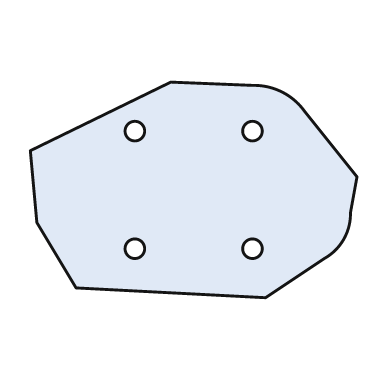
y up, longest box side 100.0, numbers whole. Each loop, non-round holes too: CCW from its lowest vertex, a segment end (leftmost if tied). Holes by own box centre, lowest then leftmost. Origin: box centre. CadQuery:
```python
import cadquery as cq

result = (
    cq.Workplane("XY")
    .moveTo(22.0, -33.0)
    .lineTo(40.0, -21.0)
    .threePointArc((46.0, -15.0), (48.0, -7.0))
    .lineTo(50.0, 4.0)
    .lineTo(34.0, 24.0)
    .threePointArc((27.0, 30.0), (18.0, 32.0))
    .lineTo(-7.0, 33.0)
    .lineTo(-50.0, 12.0)
    .lineTo(-48.0, -10.0)
    .lineTo(-36.0, -30.0)
    .close()
    .moveTo(-18.0, -18.0)
    .circle(3.0)
    .moveTo(18.0, -18.0)
    .circle(3.0)
    .moveTo(-18.0, 18.0)
    .circle(3.0)
    .moveTo(18.0, 18.0)
    .circle(3.0)
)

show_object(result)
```